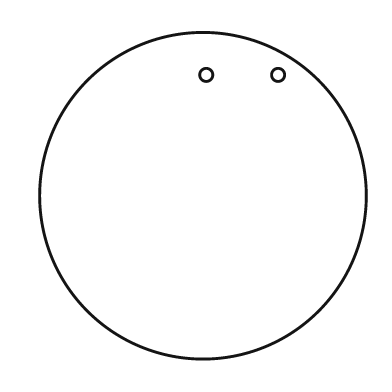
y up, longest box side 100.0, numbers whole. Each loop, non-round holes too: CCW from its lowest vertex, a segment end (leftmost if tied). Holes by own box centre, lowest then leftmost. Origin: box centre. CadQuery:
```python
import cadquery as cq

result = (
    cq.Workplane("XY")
    .moveTo(0.0, 0.0)
    .circle(50.0)
    .moveTo(1.0, 37.0)
    .circle(2.0)
    .moveTo(23.0, 37.0)
    .circle(2.0)
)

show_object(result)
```